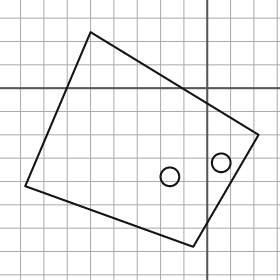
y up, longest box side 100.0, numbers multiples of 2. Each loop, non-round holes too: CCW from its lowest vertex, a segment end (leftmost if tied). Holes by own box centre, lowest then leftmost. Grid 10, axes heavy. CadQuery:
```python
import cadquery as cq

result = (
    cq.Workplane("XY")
    .moveTo(-6.0, -68.0)
    .lineTo(22.0, -20.0)
    .lineTo(-50.0, 24.0)
    .lineTo(-78.0, -42.0)
    .close()
    .moveTo(-16.0, -38.0)
    .circle(4.0)
    .moveTo(6.0, -32.0)
    .circle(4.0)
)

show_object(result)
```